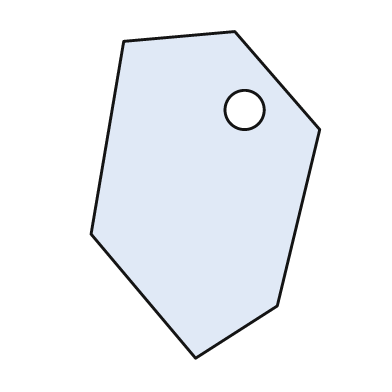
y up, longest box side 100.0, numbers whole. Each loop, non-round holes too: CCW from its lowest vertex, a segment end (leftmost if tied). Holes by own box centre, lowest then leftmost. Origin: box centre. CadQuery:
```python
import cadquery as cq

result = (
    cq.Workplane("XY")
    .moveTo(-3.0, -50.0)
    .lineTo(22.0, -34.0)
    .lineTo(35.0, 20.0)
    .lineTo(9.0, 50.0)
    .lineTo(-25.0, 47.0)
    .lineTo(-35.0, -12.0)
    .close()
    .moveTo(12.0, 26.0)
    .circle(6.0)
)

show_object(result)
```